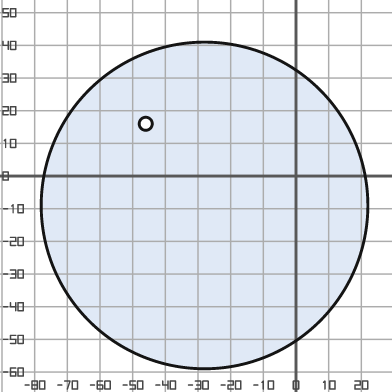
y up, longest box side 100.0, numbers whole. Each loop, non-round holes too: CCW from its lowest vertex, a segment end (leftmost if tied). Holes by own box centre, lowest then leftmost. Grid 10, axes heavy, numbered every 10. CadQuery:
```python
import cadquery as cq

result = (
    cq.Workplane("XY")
    .moveTo(-28.0, -9.0)
    .circle(50.0)
    .moveTo(-46.0, 16.0)
    .circle(2.0)
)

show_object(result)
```